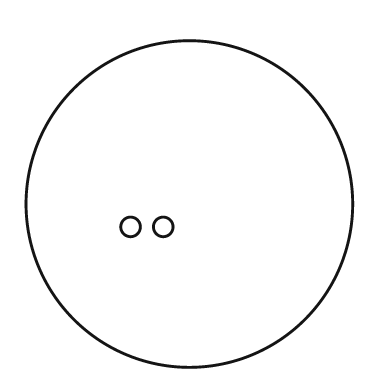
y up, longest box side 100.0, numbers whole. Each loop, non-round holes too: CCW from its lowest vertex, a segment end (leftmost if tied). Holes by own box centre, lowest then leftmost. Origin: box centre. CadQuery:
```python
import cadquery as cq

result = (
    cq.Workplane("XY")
    .moveTo(0.0, 0.0)
    .circle(50.0)
    .moveTo(-18.0, -7.0)
    .circle(3.0)
    .moveTo(-8.0, -7.0)
    .circle(3.0)
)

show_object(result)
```